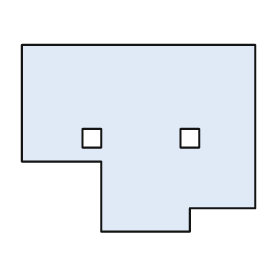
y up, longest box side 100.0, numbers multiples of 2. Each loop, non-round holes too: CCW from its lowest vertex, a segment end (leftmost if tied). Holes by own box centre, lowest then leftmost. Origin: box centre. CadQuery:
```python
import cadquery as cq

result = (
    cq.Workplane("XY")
    .moveTo(-16.0, -40.0)
    .lineTo(22.0, -40.0)
    .lineTo(22.0, -30.0)
    .lineTo(50.0, -30.0)
    .lineTo(50.0, 40.0)
    .lineTo(-50.0, 40.0)
    .lineTo(-50.0, -10.0)
    .lineTo(-16.0, -10.0)
    .close()
    .moveTo(-24.0, -4.0)
    .lineTo(-16.0, -4.0)
    .lineTo(-16.0, 4.0)
    .lineTo(-24.0, 4.0)
    .close()
    .moveTo(18.0, -4.0)
    .lineTo(26.0, -4.0)
    .lineTo(26.0, 4.0)
    .lineTo(18.0, 4.0)
    .close()
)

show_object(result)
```